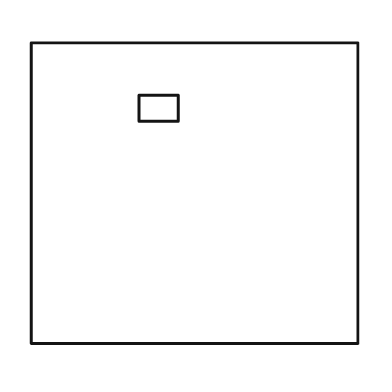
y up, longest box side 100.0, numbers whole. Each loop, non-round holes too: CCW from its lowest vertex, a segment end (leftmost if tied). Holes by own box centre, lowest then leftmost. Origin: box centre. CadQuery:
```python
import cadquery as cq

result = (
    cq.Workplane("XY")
    .moveTo(-50.0, -46.0)
    .lineTo(50.0, -46.0)
    .lineTo(50.0, 46.0)
    .lineTo(-50.0, 46.0)
    .close()
    .moveTo(-17.0, 22.0)
    .lineTo(-5.0, 22.0)
    .lineTo(-5.0, 30.0)
    .lineTo(-17.0, 30.0)
    .close()
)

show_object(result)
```